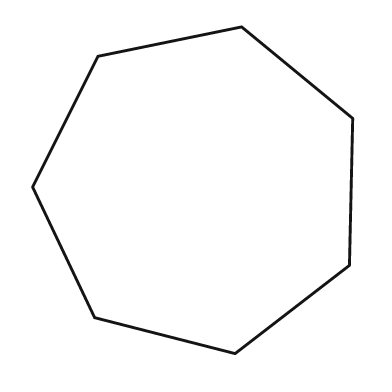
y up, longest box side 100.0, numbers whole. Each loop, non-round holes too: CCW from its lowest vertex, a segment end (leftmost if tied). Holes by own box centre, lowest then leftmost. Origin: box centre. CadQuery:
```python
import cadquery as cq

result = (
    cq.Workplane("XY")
    .moveTo(13.0, -50.0)
    .lineTo(48.0, -23.0)
    .lineTo(49.0, 22.0)
    .lineTo(15.0, 50.0)
    .lineTo(-29.0, 41.0)
    .lineTo(-49.0, 1.0)
    .lineTo(-30.0, -39.0)
    .close()
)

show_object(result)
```